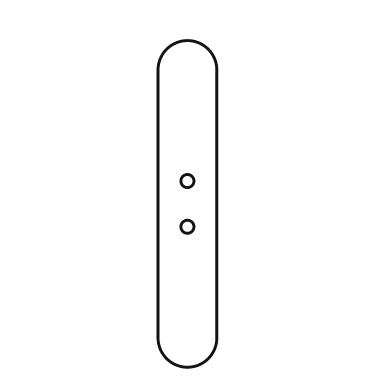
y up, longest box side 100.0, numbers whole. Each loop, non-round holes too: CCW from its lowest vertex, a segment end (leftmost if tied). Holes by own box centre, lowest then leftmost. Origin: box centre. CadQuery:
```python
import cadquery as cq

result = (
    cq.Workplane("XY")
    .moveTo(-9.0, -41.0)
    .threePointArc((0.0, -50.0), (9.0, -41.0))
    .lineTo(9.0, 41.0)
    .threePointArc((0.0, 50.0), (-9.0, 41.0))
    .close()
    .moveTo(0.0, -7.0)
    .circle(2.0)
    .moveTo(0.0, 7.0)
    .circle(2.0)
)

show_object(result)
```